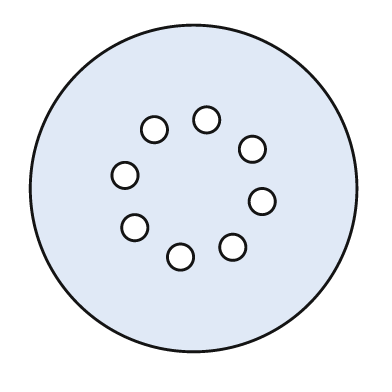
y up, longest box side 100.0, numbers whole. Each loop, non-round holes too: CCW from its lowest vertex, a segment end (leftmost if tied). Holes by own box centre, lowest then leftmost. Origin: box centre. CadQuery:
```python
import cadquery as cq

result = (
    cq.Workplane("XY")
    .moveTo(0.0, 0.0)
    .circle(50.0)
    .moveTo(-4.0, -21.0)
    .circle(4.0)
    .moveTo(12.0, -18.0)
    .circle(4.0)
    .moveTo(-18.0, -12.0)
    .circle(4.0)
    .moveTo(21.0, -4.0)
    .circle(4.0)
    .moveTo(-21.0, 4.0)
    .circle(4.0)
    .moveTo(18.0, 12.0)
    .circle(4.0)
    .moveTo(-12.0, 18.0)
    .circle(4.0)
    .moveTo(4.0, 21.0)
    .circle(4.0)
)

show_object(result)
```